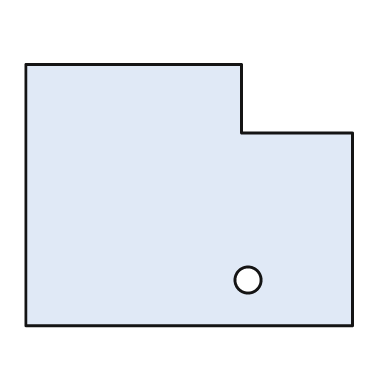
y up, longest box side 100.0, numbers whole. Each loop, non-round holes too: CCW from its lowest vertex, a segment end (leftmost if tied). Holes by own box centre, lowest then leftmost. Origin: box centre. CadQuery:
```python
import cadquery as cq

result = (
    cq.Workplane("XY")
    .moveTo(-50.0, -40.0)
    .lineTo(50.0, -40.0)
    .lineTo(50.0, 19.0)
    .lineTo(16.0, 19.0)
    .lineTo(16.0, 40.0)
    .lineTo(-50.0, 40.0)
    .close()
    .moveTo(18.0, -26.0)
    .circle(4.0)
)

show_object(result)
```